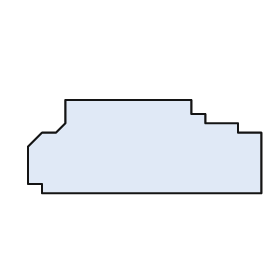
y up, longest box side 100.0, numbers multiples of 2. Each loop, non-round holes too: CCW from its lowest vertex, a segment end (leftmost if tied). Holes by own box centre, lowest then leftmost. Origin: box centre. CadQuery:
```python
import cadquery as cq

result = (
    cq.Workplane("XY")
    .moveTo(-44.0, -20.0)
    .lineTo(50.0, -20.0)
    .lineTo(50.0, 6.0)
    .lineTo(40.0, 6.0)
    .lineTo(40.0, 10.0)
    .lineTo(26.0, 10.0)
    .lineTo(26.0, 14.0)
    .lineTo(20.0, 14.0)
    .lineTo(20.0, 20.0)
    .lineTo(-34.0, 20.0)
    .lineTo(-34.0, 10.0)
    .lineTo(-38.0, 6.0)
    .lineTo(-44.0, 6.0)
    .lineTo(-50.0, 0.0)
    .lineTo(-50.0, -16.0)
    .lineTo(-44.0, -16.0)
    .close()
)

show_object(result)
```